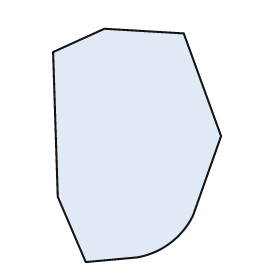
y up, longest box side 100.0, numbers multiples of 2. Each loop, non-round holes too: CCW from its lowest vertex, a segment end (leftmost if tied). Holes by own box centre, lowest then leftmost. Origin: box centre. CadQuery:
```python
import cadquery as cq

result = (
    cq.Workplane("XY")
    .moveTo(-22.0, -50.0)
    .lineTo(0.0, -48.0)
    .threePointArc((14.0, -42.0), (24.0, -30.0))
    .lineTo(36.0, 4.0)
    .lineTo(20.0, 48.0)
    .lineTo(-14.0, 50.0)
    .lineTo(-36.0, 40.0)
    .lineTo(-34.0, -22.0)
    .close()
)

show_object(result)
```